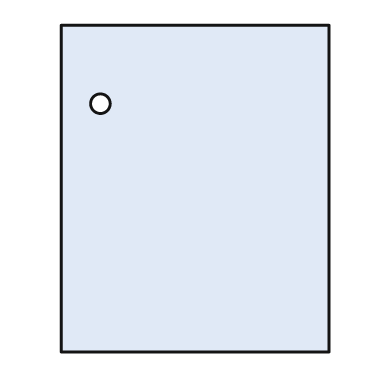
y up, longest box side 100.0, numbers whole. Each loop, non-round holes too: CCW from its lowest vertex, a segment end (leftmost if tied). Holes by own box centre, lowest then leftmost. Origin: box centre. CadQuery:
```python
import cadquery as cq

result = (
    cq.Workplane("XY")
    .moveTo(-41.0, -50.0)
    .lineTo(41.0, -50.0)
    .lineTo(41.0, 50.0)
    .lineTo(-41.0, 50.0)
    .close()
    .moveTo(-29.0, 26.0)
    .circle(3.0)
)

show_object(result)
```